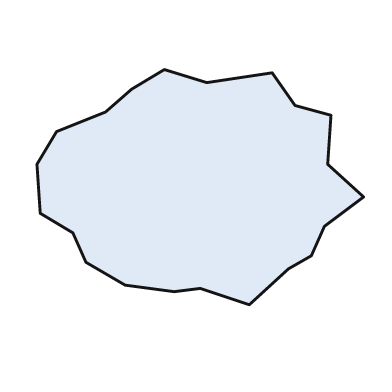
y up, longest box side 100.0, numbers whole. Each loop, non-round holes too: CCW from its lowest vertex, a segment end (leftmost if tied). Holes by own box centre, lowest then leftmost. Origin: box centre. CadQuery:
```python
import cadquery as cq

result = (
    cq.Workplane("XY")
    .moveTo(15.0, -36.0)
    .lineTo(27.0, -25.0)
    .lineTo(34.0, -21.0)
    .lineTo(38.0, -12.0)
    .lineTo(50.0, -3.0)
    .lineTo(39.0, 7.0)
    .lineTo(40.0, 22.0)
    .lineTo(29.0, 25.0)
    .lineTo(22.0, 35.0)
    .lineTo(2.0, 32.0)
    .lineTo(-11.0, 36.0)
    .lineTo(-21.0, 30.0)
    .lineTo(-29.0, 23.0)
    .lineTo(-44.0, 17.0)
    .lineTo(-50.0, 7.0)
    .lineTo(-49.0, -8.0)
    .lineTo(-39.0, -14.0)
    .lineTo(-35.0, -23.0)
    .lineTo(-23.0, -30.0)
    .lineTo(-8.0, -32.0)
    .lineTo(0.0, -31.0)
    .close()
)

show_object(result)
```